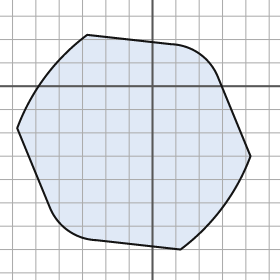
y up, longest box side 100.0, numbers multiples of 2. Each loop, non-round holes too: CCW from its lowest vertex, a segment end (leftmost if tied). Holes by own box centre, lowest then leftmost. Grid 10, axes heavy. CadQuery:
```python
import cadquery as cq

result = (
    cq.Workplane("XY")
    .moveTo(12.0, -70.0)
    .threePointArc((30.0, -52.0), (42.0, -30.0))
    .lineTo(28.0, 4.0)
    .threePointArc((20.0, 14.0), (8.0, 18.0))
    .lineTo(-28.0, 22.0)
    .threePointArc((-46.0, 4.0), (-58.0, -18.0))
    .lineTo(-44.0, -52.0)
    .threePointArc((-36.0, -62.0), (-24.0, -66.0))
    .close()
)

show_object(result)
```